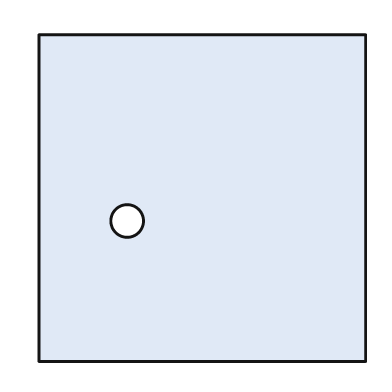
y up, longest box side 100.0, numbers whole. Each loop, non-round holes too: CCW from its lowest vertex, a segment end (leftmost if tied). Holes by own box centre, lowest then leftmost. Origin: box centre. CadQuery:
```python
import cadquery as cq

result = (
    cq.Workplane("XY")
    .moveTo(-50.0, -50.0)
    .lineTo(50.0, -50.0)
    .lineTo(50.0, 50.0)
    .lineTo(-50.0, 50.0)
    .close()
    .moveTo(-23.0, -7.0)
    .circle(5.0)
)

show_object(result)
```